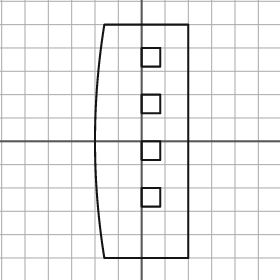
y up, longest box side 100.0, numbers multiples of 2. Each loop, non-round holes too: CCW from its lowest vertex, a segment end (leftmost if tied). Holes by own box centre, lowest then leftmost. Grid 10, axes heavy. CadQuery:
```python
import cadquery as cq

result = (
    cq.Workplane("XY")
    .moveTo(-16.0, -50.0)
    .lineTo(20.0, -50.0)
    .lineTo(20.0, 50.0)
    .lineTo(-16.0, 50.0)
    .threePointArc((-20.0, 0.0), (-16.0, -50.0))
    .close()
    .moveTo(0.0, -28.0)
    .lineTo(8.0, -28.0)
    .lineTo(8.0, -20.0)
    .lineTo(0.0, -20.0)
    .close()
    .moveTo(0.0, -8.0)
    .lineTo(8.0, -8.0)
    .lineTo(8.0, 0.0)
    .lineTo(0.0, 0.0)
    .close()
    .moveTo(0.0, 12.0)
    .lineTo(8.0, 12.0)
    .lineTo(8.0, 20.0)
    .lineTo(0.0, 20.0)
    .close()
    .moveTo(0.0, 32.0)
    .lineTo(8.0, 32.0)
    .lineTo(8.0, 40.0)
    .lineTo(0.0, 40.0)
    .close()
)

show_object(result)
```